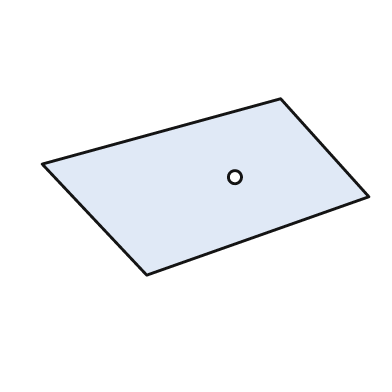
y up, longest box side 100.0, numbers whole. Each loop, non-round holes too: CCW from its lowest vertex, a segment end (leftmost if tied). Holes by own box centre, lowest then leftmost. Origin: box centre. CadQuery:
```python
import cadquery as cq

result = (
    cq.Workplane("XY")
    .moveTo(-18.0, -27.0)
    .lineTo(50.0, -3.0)
    .lineTo(23.0, 27.0)
    .lineTo(-50.0, 7.0)
    .close()
    .moveTo(9.0, 3.0)
    .circle(2.0)
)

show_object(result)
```